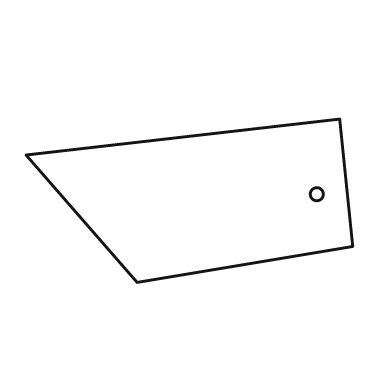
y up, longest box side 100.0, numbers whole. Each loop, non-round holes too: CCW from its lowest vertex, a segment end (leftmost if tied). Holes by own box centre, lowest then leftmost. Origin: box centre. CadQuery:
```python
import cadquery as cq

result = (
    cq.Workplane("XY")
    .moveTo(-16.0, -25.0)
    .lineTo(50.0, -14.0)
    .lineTo(46.0, 25.0)
    .lineTo(-50.0, 14.0)
    .close()
    .moveTo(39.0, 2.0)
    .circle(2.0)
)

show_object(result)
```